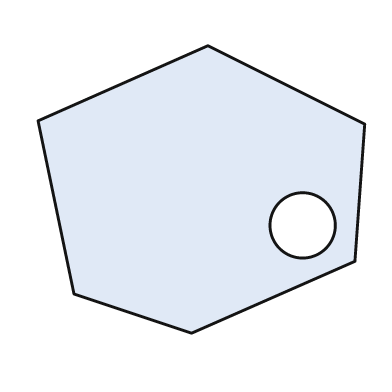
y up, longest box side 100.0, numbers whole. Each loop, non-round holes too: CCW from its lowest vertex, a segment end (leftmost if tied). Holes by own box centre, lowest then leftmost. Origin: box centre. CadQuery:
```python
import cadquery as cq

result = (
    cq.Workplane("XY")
    .moveTo(-3.0, -44.0)
    .lineTo(47.0, -22.0)
    .lineTo(50.0, 20.0)
    .lineTo(2.0, 44.0)
    .lineTo(-50.0, 21.0)
    .lineTo(-39.0, -32.0)
    .close()
    .moveTo(31.0, -11.0)
    .circle(10.0)
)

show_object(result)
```